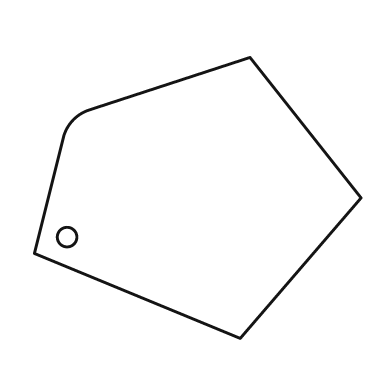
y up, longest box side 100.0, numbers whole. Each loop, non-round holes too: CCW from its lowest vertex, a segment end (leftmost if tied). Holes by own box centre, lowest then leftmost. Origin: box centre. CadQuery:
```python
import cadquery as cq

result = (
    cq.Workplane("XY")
    .moveTo(13.0, -43.0)
    .lineTo(50.0, 0.0)
    .lineTo(16.0, 43.0)
    .lineTo(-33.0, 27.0)
    .threePointArc((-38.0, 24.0), (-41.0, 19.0))
    .lineTo(-50.0, -17.0)
    .close()
    .moveTo(-40.0, -12.0)
    .circle(3.0)
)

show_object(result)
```